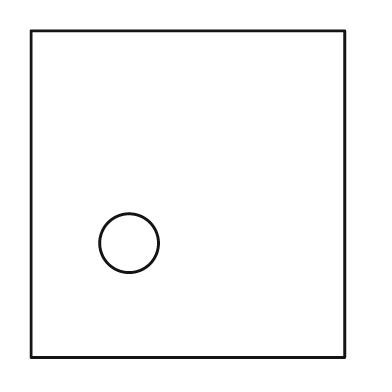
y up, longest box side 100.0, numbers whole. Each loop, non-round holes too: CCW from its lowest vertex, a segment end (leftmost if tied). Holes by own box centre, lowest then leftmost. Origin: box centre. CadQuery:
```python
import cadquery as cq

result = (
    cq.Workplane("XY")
    .moveTo(-48.0, -50.0)
    .lineTo(48.0, -50.0)
    .lineTo(48.0, 50.0)
    .lineTo(-48.0, 50.0)
    .close()
    .moveTo(-18.0, -15.0)
    .circle(9.0)
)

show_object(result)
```